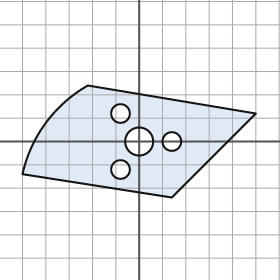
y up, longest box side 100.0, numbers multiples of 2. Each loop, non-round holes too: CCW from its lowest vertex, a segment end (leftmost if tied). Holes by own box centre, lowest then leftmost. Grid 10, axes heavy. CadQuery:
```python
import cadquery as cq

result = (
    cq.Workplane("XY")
    .moveTo(14.0, -24.0)
    .lineTo(50.0, 12.0)
    .lineTo(-22.0, 24.0)
    .threePointArc((-40.0, 8.0), (-50.0, -14.0))
    .close()
    .moveTo(-8.0, -12.0)
    .circle(4.0)
    .moveTo(0.0, 0.0)
    .circle(6.0)
    .moveTo(14.0, 0.0)
    .circle(4.0)
    .moveTo(-8.0, 12.0)
    .circle(4.0)
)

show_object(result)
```